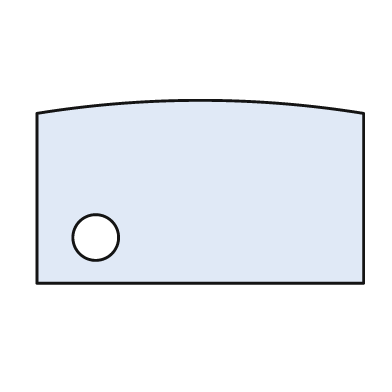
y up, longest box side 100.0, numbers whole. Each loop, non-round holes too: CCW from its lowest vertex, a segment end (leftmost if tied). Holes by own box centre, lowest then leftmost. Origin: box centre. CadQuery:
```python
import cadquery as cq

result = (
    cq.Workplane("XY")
    .moveTo(-50.0, -28.0)
    .lineTo(50.0, -28.0)
    .lineTo(50.0, 24.0)
    .threePointArc((0.0, 28.0), (-50.0, 24.0))
    .close()
    .moveTo(-32.0, -14.0)
    .circle(7.0)
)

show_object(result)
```